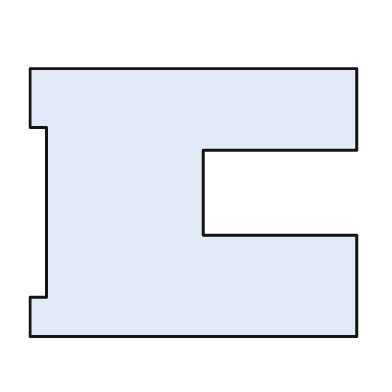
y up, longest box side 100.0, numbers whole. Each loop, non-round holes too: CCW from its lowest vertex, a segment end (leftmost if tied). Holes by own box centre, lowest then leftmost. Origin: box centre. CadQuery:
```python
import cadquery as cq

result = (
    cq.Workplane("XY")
    .moveTo(-50.0, -41.0)
    .lineTo(50.0, -41.0)
    .lineTo(50.0, -10.0)
    .lineTo(3.0, -10.0)
    .lineTo(3.0, 16.0)
    .lineTo(50.0, 16.0)
    .lineTo(50.0, 41.0)
    .lineTo(-50.0, 41.0)
    .lineTo(-50.0, 23.0)
    .lineTo(-45.0, 23.0)
    .lineTo(-45.0, -29.0)
    .lineTo(-50.0, -29.0)
    .close()
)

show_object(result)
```